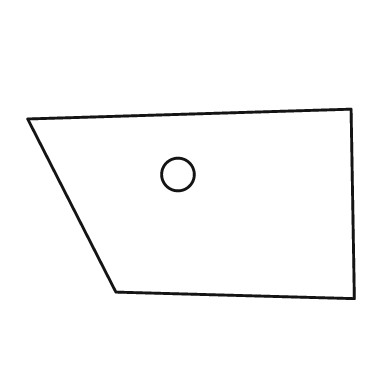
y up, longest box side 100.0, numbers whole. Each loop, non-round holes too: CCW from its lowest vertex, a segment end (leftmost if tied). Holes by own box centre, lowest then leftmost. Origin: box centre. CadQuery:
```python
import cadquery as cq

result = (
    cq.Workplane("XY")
    .moveTo(50.0, -29.0)
    .lineTo(49.0, 29.0)
    .lineTo(-50.0, 26.0)
    .lineTo(-23.0, -27.0)
    .close()
    .moveTo(-4.0, 9.0)
    .circle(5.0)
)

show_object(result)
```